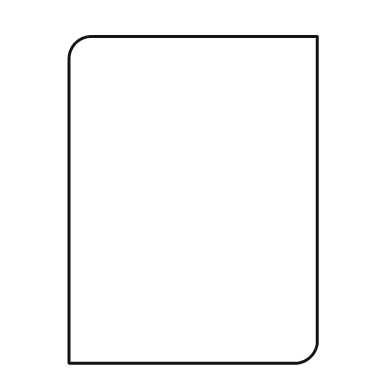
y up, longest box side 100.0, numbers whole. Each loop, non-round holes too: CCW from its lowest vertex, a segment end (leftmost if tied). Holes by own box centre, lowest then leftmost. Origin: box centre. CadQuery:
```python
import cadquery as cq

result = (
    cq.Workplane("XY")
    .moveTo(-38.0, -50.0)
    .lineTo(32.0, -50.0)
    .threePointArc((36.0, -48.0), (38.0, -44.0))
    .lineTo(38.0, 50.0)
    .lineTo(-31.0, 50.0)
    .threePointArc((-36.0, 48.0), (-38.0, 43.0))
    .close()
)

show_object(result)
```